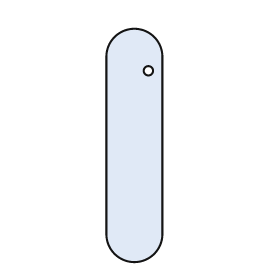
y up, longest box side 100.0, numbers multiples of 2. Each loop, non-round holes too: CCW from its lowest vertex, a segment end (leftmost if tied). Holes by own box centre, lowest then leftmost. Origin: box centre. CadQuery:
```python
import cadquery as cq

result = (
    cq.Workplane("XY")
    .moveTo(-12.0, -38.0)
    .threePointArc((0.0, -50.0), (12.0, -38.0))
    .lineTo(12.0, 38.0)
    .threePointArc((0.0, 50.0), (-12.0, 38.0))
    .close()
    .moveTo(6.0, 32.0)
    .circle(2.0)
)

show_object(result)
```